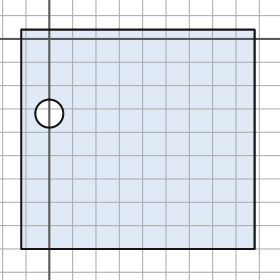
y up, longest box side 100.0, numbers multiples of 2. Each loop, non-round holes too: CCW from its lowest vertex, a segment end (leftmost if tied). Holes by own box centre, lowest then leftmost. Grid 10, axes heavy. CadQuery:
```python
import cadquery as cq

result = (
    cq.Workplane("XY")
    .moveTo(-12.0, -90.0)
    .lineTo(88.0, -90.0)
    .lineTo(88.0, 4.0)
    .lineTo(-12.0, 4.0)
    .close()
    .moveTo(0.0, -32.0)
    .circle(6.0)
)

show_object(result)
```